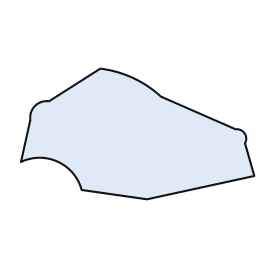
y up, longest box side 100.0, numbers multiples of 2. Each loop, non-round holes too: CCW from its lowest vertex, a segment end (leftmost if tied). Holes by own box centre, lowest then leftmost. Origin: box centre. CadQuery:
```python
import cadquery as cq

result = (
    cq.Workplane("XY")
    .moveTo(4.0, -28.0)
    .lineTo(50.0, -18.0)
    .lineTo(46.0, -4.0)
    .threePointArc((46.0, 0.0), (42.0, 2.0))
    .lineTo(10.0, 16.0)
    .threePointArc((-2.0, 24.0), (-16.0, 28.0))
    .lineTo(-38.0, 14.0)
    .threePointArc((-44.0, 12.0), (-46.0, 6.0))
    .lineTo(-50.0, -12.0)
    .threePointArc((-34.0, -12.0), (-24.0, -24.0))
    .close()
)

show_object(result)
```